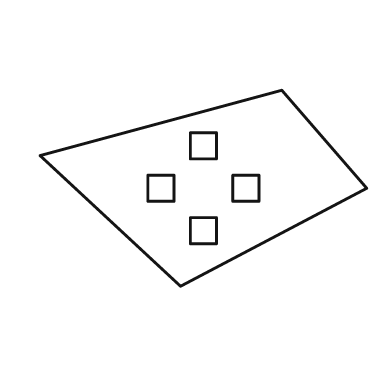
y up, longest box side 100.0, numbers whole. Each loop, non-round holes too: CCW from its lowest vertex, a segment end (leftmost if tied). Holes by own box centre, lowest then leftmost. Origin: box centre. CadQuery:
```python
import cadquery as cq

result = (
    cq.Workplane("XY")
    .moveTo(-7.0, -30.0)
    .lineTo(50.0, 0.0)
    .lineTo(24.0, 30.0)
    .lineTo(-50.0, 10.0)
    .close()
    .moveTo(-4.0, -17.0)
    .lineTo(4.0, -17.0)
    .lineTo(4.0, -9.0)
    .lineTo(-4.0, -9.0)
    .close()
    .moveTo(-17.0, -4.0)
    .lineTo(-9.0, -4.0)
    .lineTo(-9.0, 4.0)
    .lineTo(-17.0, 4.0)
    .close()
    .moveTo(9.0, -4.0)
    .lineTo(17.0, -4.0)
    .lineTo(17.0, 4.0)
    .lineTo(9.0, 4.0)
    .close()
    .moveTo(-4.0, 9.0)
    .lineTo(4.0, 9.0)
    .lineTo(4.0, 17.0)
    .lineTo(-4.0, 17.0)
    .close()
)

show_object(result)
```